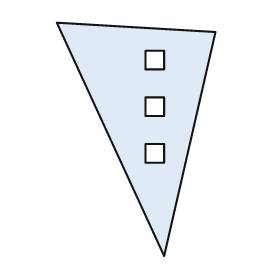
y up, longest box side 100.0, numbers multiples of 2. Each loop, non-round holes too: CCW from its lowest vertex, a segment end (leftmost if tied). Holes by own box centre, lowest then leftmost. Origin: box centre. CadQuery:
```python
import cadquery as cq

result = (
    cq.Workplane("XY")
    .moveTo(12.0, -50.0)
    .lineTo(34.0, 46.0)
    .lineTo(-34.0, 50.0)
    .close()
    .moveTo(4.0, -10.0)
    .lineTo(12.0, -10.0)
    .lineTo(12.0, -2.0)
    .lineTo(4.0, -2.0)
    .close()
    .moveTo(4.0, 10.0)
    .lineTo(12.0, 10.0)
    .lineTo(12.0, 18.0)
    .lineTo(4.0, 18.0)
    .close()
    .moveTo(4.0, 30.0)
    .lineTo(12.0, 30.0)
    .lineTo(12.0, 38.0)
    .lineTo(4.0, 38.0)
    .close()
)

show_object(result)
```